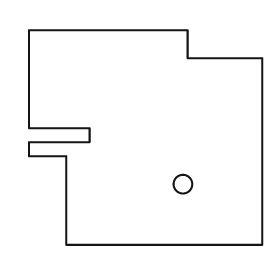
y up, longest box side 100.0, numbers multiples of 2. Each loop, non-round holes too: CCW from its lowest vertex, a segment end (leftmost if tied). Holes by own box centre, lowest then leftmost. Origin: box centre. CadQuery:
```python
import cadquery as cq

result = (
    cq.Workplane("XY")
    .moveTo(-34.0, -46.0)
    .lineTo(50.0, -46.0)
    .lineTo(50.0, 34.0)
    .lineTo(18.0, 34.0)
    .lineTo(18.0, 46.0)
    .lineTo(-50.0, 46.0)
    .lineTo(-50.0, 4.0)
    .lineTo(-24.0, 4.0)
    .lineTo(-24.0, -2.0)
    .lineTo(-50.0, -2.0)
    .lineTo(-50.0, -8.0)
    .lineTo(-34.0, -8.0)
    .close()
    .moveTo(16.0, -20.0)
    .circle(4.0)
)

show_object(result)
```